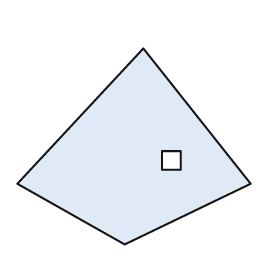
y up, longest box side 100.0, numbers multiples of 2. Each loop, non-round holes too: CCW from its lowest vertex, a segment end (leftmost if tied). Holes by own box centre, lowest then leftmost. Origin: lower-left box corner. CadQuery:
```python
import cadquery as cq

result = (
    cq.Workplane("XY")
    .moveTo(46.0, 0.0)
    .lineTo(100.0, 26.0)
    .lineTo(54.0, 84.0)
    .lineTo(0.0, 26.0)
    .close()
    .moveTo(62.0, 32.0)
    .lineTo(70.0, 32.0)
    .lineTo(70.0, 40.0)
    .lineTo(62.0, 40.0)
    .close()
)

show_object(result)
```